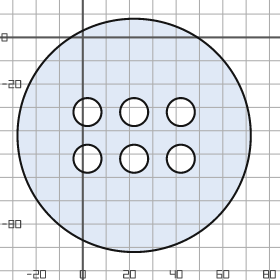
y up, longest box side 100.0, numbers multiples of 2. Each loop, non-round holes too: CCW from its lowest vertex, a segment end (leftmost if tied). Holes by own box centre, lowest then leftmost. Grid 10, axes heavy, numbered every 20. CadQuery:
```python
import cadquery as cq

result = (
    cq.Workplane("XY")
    .moveTo(22.0, -42.0)
    .circle(50.0)
    .moveTo(2.0, -52.0)
    .circle(6.0)
    .moveTo(22.0, -52.0)
    .circle(6.0)
    .moveTo(42.0, -52.0)
    .circle(6.0)
    .moveTo(2.0, -32.0)
    .circle(6.0)
    .moveTo(22.0, -32.0)
    .circle(6.0)
    .moveTo(42.0, -32.0)
    .circle(6.0)
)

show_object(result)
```